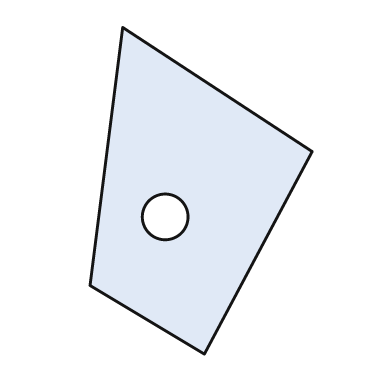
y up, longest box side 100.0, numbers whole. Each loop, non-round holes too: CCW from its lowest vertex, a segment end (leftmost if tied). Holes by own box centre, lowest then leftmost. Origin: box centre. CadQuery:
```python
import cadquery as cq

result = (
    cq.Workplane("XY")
    .moveTo(1.0, -50.0)
    .lineTo(34.0, 12.0)
    .lineTo(-24.0, 50.0)
    .lineTo(-34.0, -29.0)
    .close()
    .moveTo(-11.0, -8.0)
    .circle(7.0)
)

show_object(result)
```